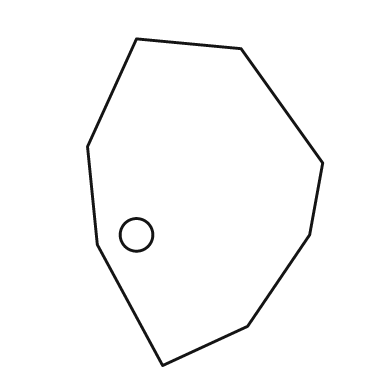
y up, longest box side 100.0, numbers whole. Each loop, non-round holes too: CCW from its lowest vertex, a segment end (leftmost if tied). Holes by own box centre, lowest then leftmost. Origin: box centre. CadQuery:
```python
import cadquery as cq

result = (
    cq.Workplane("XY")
    .moveTo(-13.0, -50.0)
    .lineTo(13.0, -38.0)
    .lineTo(32.0, -10.0)
    .lineTo(36.0, 12.0)
    .lineTo(11.0, 47.0)
    .lineTo(-21.0, 50.0)
    .lineTo(-36.0, 17.0)
    .lineTo(-33.0, -13.0)
    .close()
    .moveTo(-21.0, -10.0)
    .circle(5.0)
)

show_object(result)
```